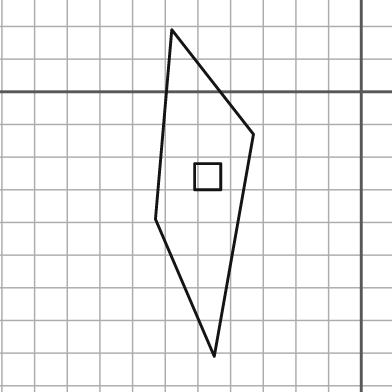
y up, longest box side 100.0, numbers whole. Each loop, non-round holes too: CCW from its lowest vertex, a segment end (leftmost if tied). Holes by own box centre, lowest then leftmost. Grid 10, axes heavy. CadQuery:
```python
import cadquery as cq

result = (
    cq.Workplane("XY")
    .moveTo(-45.0, -81.0)
    .lineTo(-33.0, -13.0)
    .lineTo(-58.0, 19.0)
    .lineTo(-63.0, -39.0)
    .close()
    .moveTo(-51.0, -30.0)
    .lineTo(-43.0, -30.0)
    .lineTo(-43.0, -22.0)
    .lineTo(-51.0, -22.0)
    .close()
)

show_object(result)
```